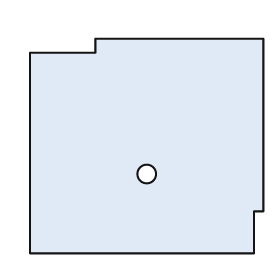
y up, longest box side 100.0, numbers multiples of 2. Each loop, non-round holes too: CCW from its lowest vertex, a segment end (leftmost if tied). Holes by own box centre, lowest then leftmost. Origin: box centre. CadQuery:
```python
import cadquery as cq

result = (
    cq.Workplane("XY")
    .moveTo(-50.0, -46.0)
    .lineTo(46.0, -46.0)
    .lineTo(46.0, -28.0)
    .lineTo(50.0, -28.0)
    .lineTo(50.0, 46.0)
    .lineTo(-22.0, 46.0)
    .lineTo(-22.0, 40.0)
    .lineTo(-50.0, 40.0)
    .close()
    .moveTo(0.0, -12.0)
    .circle(4.0)
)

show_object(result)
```